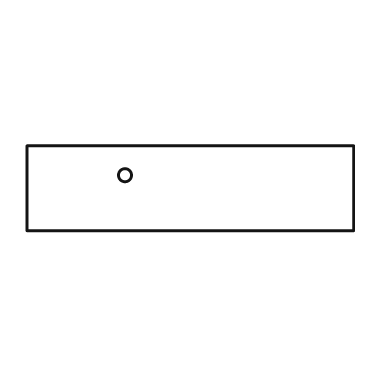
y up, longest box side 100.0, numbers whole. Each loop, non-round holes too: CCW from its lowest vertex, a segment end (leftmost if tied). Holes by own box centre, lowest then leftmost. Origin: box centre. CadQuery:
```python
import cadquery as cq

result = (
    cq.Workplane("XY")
    .moveTo(-50.0, -13.0)
    .lineTo(50.0, -13.0)
    .lineTo(50.0, 13.0)
    .lineTo(-50.0, 13.0)
    .close()
    .moveTo(-20.0, 4.0)
    .circle(2.0)
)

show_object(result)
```